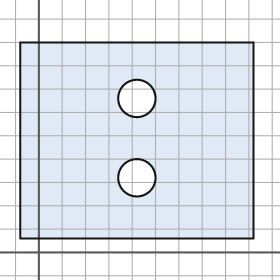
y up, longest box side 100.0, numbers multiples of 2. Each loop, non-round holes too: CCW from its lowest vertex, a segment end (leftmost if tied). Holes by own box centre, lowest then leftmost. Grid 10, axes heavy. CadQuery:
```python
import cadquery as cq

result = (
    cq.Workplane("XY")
    .moveTo(-8.0, 6.0)
    .lineTo(92.0, 6.0)
    .lineTo(92.0, 90.0)
    .lineTo(-8.0, 90.0)
    .close()
    .moveTo(42.0, 32.0)
    .circle(8.0)
    .moveTo(42.0, 66.0)
    .circle(8.0)
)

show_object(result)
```